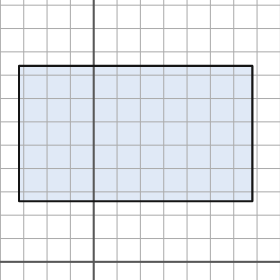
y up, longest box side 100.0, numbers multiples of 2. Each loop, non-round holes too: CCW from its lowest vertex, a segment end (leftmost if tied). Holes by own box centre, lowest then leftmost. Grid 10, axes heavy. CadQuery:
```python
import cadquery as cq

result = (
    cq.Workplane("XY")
    .moveTo(-32.0, 26.0)
    .lineTo(68.0, 26.0)
    .lineTo(68.0, 84.0)
    .lineTo(-32.0, 84.0)
    .close()
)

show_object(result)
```